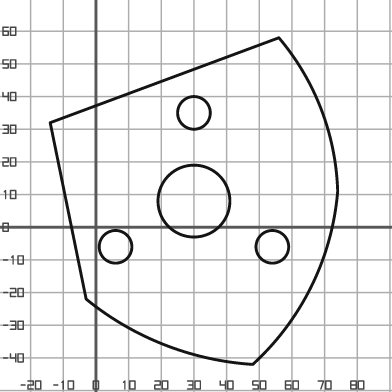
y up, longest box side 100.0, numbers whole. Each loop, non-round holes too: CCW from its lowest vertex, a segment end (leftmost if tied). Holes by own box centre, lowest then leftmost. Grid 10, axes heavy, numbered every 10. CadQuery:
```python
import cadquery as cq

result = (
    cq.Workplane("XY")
    .moveTo(48.0, -42.0)
    .threePointArc((66.0, -18.0), (74.0, 11.0))
    .threePointArc((69.0, 36.0), (56.0, 58.0))
    .lineTo(-14.0, 32.0)
    .lineTo(-3.0, -22.0)
    .threePointArc((21.0, -36.0), (48.0, -42.0))
    .close()
    .moveTo(6.0, -6.0)
    .circle(5.0)
    .moveTo(54.0, -6.0)
    .circle(5.0)
    .moveTo(30.0, 8.0)
    .circle(11.0)
    .moveTo(30.0, 35.0)
    .circle(5.0)
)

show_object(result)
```